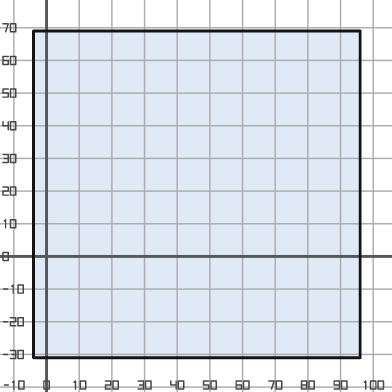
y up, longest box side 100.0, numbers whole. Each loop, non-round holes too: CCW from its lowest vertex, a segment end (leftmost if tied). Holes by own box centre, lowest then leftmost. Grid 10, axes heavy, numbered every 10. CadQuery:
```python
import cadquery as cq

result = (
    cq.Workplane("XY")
    .moveTo(-4.0, -31.0)
    .lineTo(96.0, -31.0)
    .lineTo(96.0, 69.0)
    .lineTo(-4.0, 69.0)
    .close()
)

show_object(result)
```